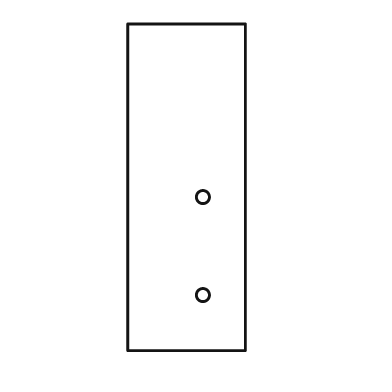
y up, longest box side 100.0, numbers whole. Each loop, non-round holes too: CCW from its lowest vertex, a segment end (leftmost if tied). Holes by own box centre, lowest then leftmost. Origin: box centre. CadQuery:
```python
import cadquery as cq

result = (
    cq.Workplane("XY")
    .moveTo(-18.0, -50.0)
    .lineTo(18.0, -50.0)
    .lineTo(18.0, 50.0)
    .lineTo(-18.0, 50.0)
    .close()
    .moveTo(5.0, -33.0)
    .circle(2.0)
    .moveTo(5.0, -3.0)
    .circle(2.0)
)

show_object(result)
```